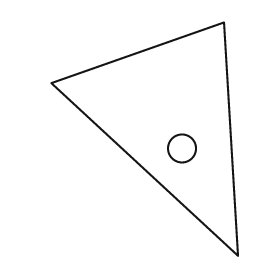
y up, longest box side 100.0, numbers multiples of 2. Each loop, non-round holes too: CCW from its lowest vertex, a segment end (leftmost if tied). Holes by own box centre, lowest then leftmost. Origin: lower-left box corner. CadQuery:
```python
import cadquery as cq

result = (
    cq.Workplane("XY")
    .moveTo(80.0, 0.0)
    .lineTo(74.0, 100.0)
    .lineTo(0.0, 74.0)
    .close()
    .moveTo(56.0, 46.0)
    .circle(6.0)
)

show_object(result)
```